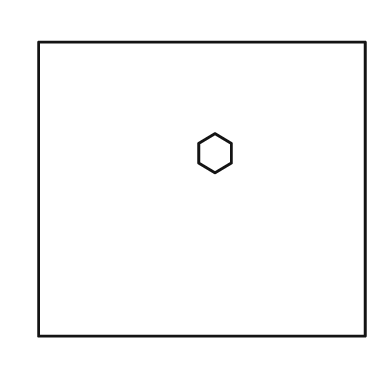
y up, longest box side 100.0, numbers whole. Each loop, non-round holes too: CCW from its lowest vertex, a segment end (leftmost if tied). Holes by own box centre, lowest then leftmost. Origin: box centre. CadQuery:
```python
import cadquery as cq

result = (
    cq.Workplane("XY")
    .moveTo(-50.0, -45.0)
    .lineTo(50.0, -45.0)
    .lineTo(50.0, 45.0)
    .lineTo(-50.0, 45.0)
    .close()
    .moveTo(4.0, 5.0)
    .lineTo(9.0, 8.0)
    .lineTo(9.0, 14.0)
    .lineTo(4.0, 17.0)
    .lineTo(-1.0, 14.0)
    .lineTo(-1.0, 8.0)
    .close()
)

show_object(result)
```